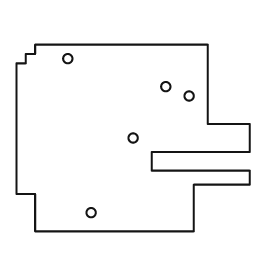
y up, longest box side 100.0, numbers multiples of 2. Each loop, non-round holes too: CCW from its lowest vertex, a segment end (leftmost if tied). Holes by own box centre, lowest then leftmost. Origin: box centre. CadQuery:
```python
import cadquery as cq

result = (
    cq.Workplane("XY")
    .moveTo(-42.0, -40.0)
    .lineTo(26.0, -40.0)
    .lineTo(26.0, -20.0)
    .lineTo(50.0, -20.0)
    .lineTo(50.0, -14.0)
    .lineTo(8.0, -14.0)
    .lineTo(8.0, -6.0)
    .lineTo(50.0, -6.0)
    .lineTo(50.0, 6.0)
    .lineTo(32.0, 6.0)
    .lineTo(32.0, 40.0)
    .lineTo(-42.0, 40.0)
    .lineTo(-42.0, 36.0)
    .lineTo(-46.0, 36.0)
    .lineTo(-46.0, 32.0)
    .lineTo(-50.0, 32.0)
    .lineTo(-50.0, -24.0)
    .lineTo(-42.0, -24.0)
    .close()
    .moveTo(-18.0, -32.0)
    .circle(2.0)
    .moveTo(0.0, 0.0)
    .circle(2.0)
    .moveTo(24.0, 18.0)
    .circle(2.0)
    .moveTo(14.0, 22.0)
    .circle(2.0)
    .moveTo(-28.0, 34.0)
    .circle(2.0)
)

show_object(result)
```